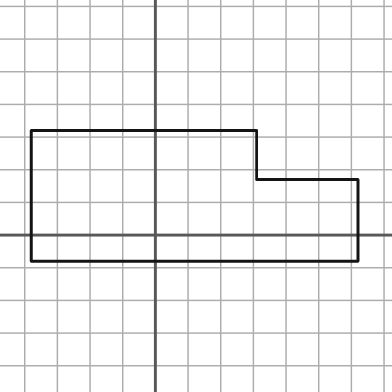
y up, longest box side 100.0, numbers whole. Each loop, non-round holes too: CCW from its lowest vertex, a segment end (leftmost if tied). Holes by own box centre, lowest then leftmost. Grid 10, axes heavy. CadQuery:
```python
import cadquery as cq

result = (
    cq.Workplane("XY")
    .moveTo(-38.0, -8.0)
    .lineTo(62.0, -8.0)
    .lineTo(62.0, 17.0)
    .lineTo(31.0, 17.0)
    .lineTo(31.0, 32.0)
    .lineTo(-38.0, 32.0)
    .close()
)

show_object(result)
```